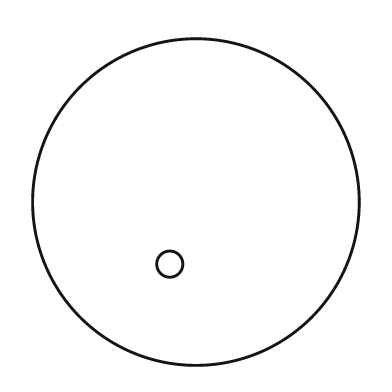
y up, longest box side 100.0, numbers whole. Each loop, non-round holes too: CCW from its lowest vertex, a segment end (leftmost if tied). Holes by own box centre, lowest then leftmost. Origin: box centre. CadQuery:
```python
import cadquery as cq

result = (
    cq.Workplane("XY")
    .moveTo(0.0, 0.0)
    .circle(50.0)
    .moveTo(-8.0, -19.0)
    .circle(4.0)
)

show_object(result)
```